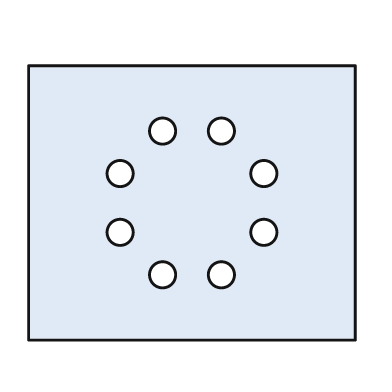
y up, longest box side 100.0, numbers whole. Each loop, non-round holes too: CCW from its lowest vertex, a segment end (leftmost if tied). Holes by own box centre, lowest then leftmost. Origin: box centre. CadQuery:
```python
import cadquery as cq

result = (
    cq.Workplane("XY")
    .moveTo(-50.0, -42.0)
    .lineTo(50.0, -42.0)
    .lineTo(50.0, 42.0)
    .lineTo(-50.0, 42.0)
    .close()
    .moveTo(-9.0, -22.0)
    .circle(4.0)
    .moveTo(9.0, -22.0)
    .circle(4.0)
    .moveTo(-22.0, -9.0)
    .circle(4.0)
    .moveTo(22.0, -9.0)
    .circle(4.0)
    .moveTo(-22.0, 9.0)
    .circle(4.0)
    .moveTo(22.0, 9.0)
    .circle(4.0)
    .moveTo(-9.0, 22.0)
    .circle(4.0)
    .moveTo(9.0, 22.0)
    .circle(4.0)
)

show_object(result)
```